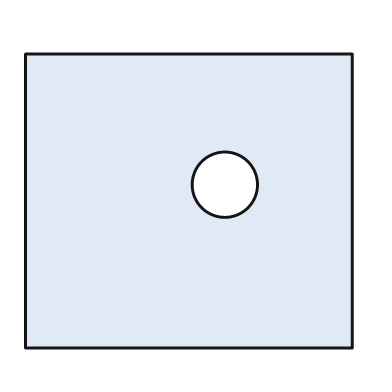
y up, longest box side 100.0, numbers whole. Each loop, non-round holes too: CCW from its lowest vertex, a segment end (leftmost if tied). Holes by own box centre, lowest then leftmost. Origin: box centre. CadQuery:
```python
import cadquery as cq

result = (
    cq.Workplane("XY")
    .moveTo(-50.0, -45.0)
    .lineTo(50.0, -45.0)
    .lineTo(50.0, 45.0)
    .lineTo(-50.0, 45.0)
    .close()
    .moveTo(11.0, 5.0)
    .circle(10.0)
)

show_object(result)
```